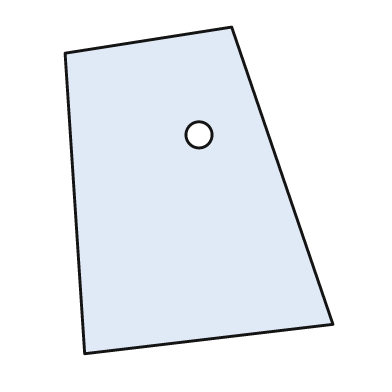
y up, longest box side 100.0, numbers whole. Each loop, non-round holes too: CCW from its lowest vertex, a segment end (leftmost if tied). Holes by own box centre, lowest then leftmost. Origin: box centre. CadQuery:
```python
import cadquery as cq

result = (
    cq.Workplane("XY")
    .moveTo(-35.0, -50.0)
    .lineTo(41.0, -41.0)
    .lineTo(10.0, 50.0)
    .lineTo(-41.0, 42.0)
    .close()
    .moveTo(0.0, 17.0)
    .circle(4.0)
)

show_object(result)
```